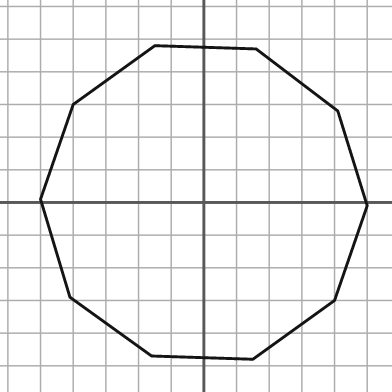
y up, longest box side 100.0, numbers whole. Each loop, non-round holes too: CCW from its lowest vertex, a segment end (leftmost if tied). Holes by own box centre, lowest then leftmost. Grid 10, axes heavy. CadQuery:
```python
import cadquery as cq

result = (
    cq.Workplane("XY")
    .moveTo(15.0, -48.0)
    .lineTo(40.0, -30.0)
    .lineTo(50.0, -1.0)
    .lineTo(41.0, 28.0)
    .lineTo(16.0, 47.0)
    .lineTo(-15.0, 48.0)
    .lineTo(-40.0, 30.0)
    .lineTo(-50.0, 1.0)
    .lineTo(-41.0, -29.0)
    .lineTo(-16.0, -47.0)
    .close()
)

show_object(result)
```